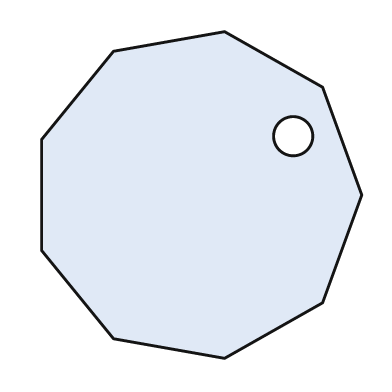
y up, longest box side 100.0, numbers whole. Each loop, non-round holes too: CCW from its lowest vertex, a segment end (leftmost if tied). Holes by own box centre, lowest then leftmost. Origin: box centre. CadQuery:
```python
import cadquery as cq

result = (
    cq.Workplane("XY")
    .moveTo(7.0, -50.0)
    .lineTo(37.0, -33.0)
    .lineTo(49.0, 0.0)
    .lineTo(37.0, 33.0)
    .lineTo(7.0, 50.0)
    .lineTo(-27.0, 44.0)
    .lineTo(-49.0, 17.0)
    .lineTo(-49.0, -17.0)
    .lineTo(-27.0, -44.0)
    .close()
    .moveTo(28.0, 18.0)
    .circle(6.0)
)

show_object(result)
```